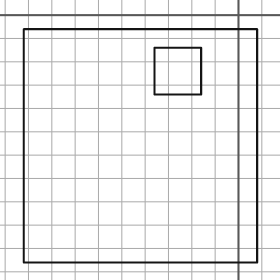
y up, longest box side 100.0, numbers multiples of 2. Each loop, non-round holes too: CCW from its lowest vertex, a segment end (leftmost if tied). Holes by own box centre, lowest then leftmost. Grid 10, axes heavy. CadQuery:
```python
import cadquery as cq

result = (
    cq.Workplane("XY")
    .moveTo(-92.0, -106.0)
    .lineTo(8.0, -106.0)
    .lineTo(8.0, -6.0)
    .lineTo(-92.0, -6.0)
    .close()
    .moveTo(-36.0, -34.0)
    .lineTo(-16.0, -34.0)
    .lineTo(-16.0, -14.0)
    .lineTo(-36.0, -14.0)
    .close()
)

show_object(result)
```